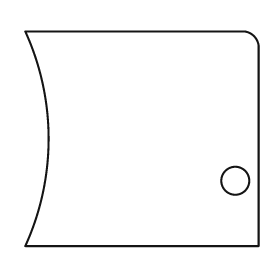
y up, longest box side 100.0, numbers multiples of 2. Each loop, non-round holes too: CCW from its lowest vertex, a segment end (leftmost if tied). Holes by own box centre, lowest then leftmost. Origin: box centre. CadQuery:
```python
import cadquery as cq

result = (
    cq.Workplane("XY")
    .moveTo(-50.0, -46.0)
    .lineTo(50.0, -46.0)
    .lineTo(50.0, 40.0)
    .threePointArc((48.0, 44.0), (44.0, 46.0))
    .lineTo(-50.0, 46.0)
    .threePointArc((-40.0, 0.0), (-50.0, -46.0))
    .close()
    .moveTo(40.0, -18.0)
    .circle(6.0)
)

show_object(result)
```